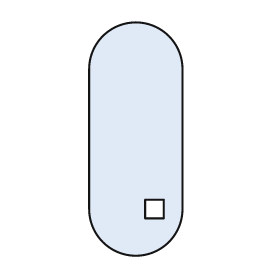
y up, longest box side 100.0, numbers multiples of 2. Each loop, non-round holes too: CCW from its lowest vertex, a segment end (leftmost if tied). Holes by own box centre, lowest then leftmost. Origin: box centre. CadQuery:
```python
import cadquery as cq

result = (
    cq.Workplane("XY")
    .moveTo(-20.0, -30.0)
    .threePointArc((0.0, -50.0), (20.0, -30.0))
    .lineTo(20.0, 30.0)
    .threePointArc((0.0, 50.0), (-20.0, 30.0))
    .close()
    .moveTo(4.0, -34.0)
    .lineTo(12.0, -34.0)
    .lineTo(12.0, -26.0)
    .lineTo(4.0, -26.0)
    .close()
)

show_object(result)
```